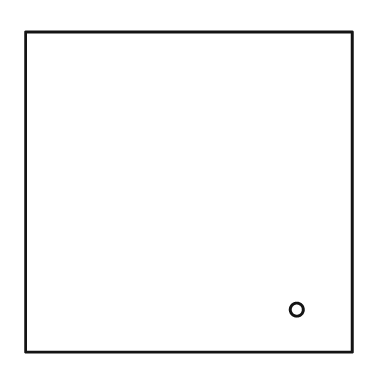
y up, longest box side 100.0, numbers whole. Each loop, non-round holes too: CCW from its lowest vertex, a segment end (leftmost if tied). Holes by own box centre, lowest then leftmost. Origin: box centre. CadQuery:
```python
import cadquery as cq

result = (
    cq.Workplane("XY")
    .moveTo(-50.0, -49.0)
    .lineTo(50.0, -49.0)
    .lineTo(50.0, 49.0)
    .lineTo(-50.0, 49.0)
    .close()
    .moveTo(33.0, -36.0)
    .circle(2.0)
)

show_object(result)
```